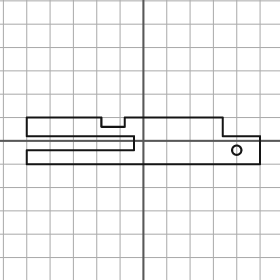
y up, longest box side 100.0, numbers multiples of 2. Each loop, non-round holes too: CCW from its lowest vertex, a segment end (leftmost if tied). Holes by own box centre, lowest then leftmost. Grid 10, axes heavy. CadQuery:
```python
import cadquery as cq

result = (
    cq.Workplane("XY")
    .moveTo(-50.0, -10.0)
    .lineTo(50.0, -10.0)
    .lineTo(50.0, 2.0)
    .lineTo(34.0, 2.0)
    .lineTo(34.0, 10.0)
    .lineTo(-8.0, 10.0)
    .lineTo(-8.0, 6.0)
    .lineTo(-18.0, 6.0)
    .lineTo(-18.0, 10.0)
    .lineTo(-50.0, 10.0)
    .lineTo(-50.0, 2.0)
    .lineTo(-4.0, 2.0)
    .lineTo(-4.0, -4.0)
    .lineTo(-50.0, -4.0)
    .close()
    .moveTo(40.0, -4.0)
    .circle(2.0)
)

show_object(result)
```